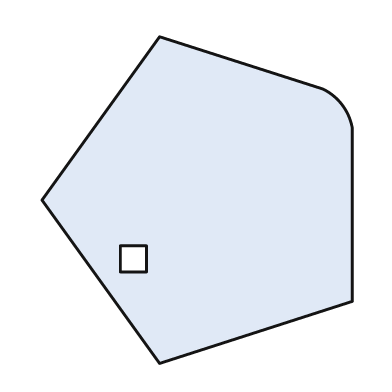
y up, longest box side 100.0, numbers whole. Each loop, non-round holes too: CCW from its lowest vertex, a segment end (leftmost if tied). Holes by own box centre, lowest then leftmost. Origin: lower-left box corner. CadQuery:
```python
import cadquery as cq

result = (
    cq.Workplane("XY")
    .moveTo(36.0, 0.0)
    .lineTo(95.0, 19.0)
    .lineTo(95.0, 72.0)
    .threePointArc((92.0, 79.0), (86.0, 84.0))
    .lineTo(36.0, 100.0)
    .lineTo(0.0, 50.0)
    .close()
    .moveTo(24.0, 28.0)
    .lineTo(32.0, 28.0)
    .lineTo(32.0, 36.0)
    .lineTo(24.0, 36.0)
    .close()
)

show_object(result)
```